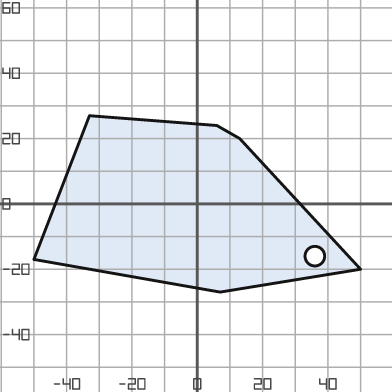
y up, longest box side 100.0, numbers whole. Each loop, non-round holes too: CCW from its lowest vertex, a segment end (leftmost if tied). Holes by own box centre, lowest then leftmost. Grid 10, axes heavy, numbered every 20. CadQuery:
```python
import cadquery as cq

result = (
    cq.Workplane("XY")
    .moveTo(7.0, -27.0)
    .lineTo(50.0, -20.0)
    .lineTo(13.0, 20.0)
    .lineTo(6.0, 24.0)
    .lineTo(-33.0, 27.0)
    .lineTo(-50.0, -17.0)
    .close()
    .moveTo(36.0, -16.0)
    .circle(3.0)
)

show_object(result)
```